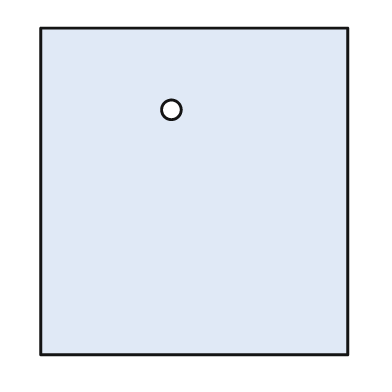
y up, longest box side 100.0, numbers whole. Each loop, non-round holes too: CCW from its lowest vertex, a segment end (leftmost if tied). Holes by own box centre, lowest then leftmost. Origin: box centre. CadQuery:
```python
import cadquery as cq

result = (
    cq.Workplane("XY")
    .moveTo(-47.0, -50.0)
    .lineTo(47.0, -50.0)
    .lineTo(47.0, 50.0)
    .lineTo(-47.0, 50.0)
    .close()
    .moveTo(-7.0, 25.0)
    .circle(3.0)
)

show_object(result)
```